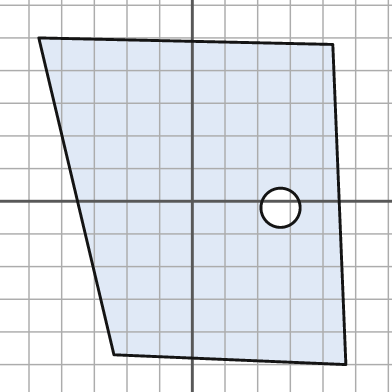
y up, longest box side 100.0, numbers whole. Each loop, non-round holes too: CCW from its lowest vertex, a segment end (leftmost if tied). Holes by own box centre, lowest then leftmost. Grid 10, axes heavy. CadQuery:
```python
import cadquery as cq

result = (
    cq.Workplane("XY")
    .moveTo(47.0, -50.0)
    .lineTo(43.0, 48.0)
    .lineTo(-47.0, 50.0)
    .lineTo(-24.0, -47.0)
    .close()
    .moveTo(27.0, -2.0)
    .circle(6.0)
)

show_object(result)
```